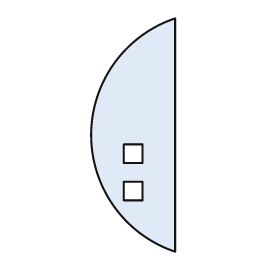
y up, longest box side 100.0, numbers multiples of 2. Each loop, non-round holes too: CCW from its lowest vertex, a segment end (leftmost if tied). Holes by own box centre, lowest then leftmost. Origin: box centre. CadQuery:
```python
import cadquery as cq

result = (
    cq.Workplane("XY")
    .moveTo(18.0, -50.0)
    .lineTo(18.0, 50.0)
    .threePointArc((-18.0, 0.0), (18.0, -50.0))
    .close()
    .moveTo(-4.0, -28.0)
    .lineTo(4.0, -28.0)
    .lineTo(4.0, -20.0)
    .lineTo(-4.0, -20.0)
    .close()
    .moveTo(-4.0, -12.0)
    .lineTo(4.0, -12.0)
    .lineTo(4.0, -4.0)
    .lineTo(-4.0, -4.0)
    .close()
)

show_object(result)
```